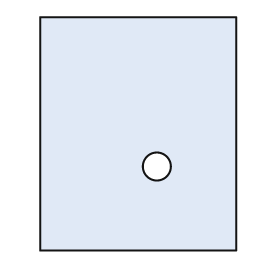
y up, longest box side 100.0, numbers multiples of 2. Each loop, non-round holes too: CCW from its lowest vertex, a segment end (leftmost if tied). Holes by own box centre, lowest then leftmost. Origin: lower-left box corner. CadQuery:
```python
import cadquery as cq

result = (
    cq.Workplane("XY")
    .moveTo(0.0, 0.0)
    .lineTo(84.0, 0.0)
    .lineTo(84.0, 100.0)
    .lineTo(0.0, 100.0)
    .close()
    .moveTo(50.0, 36.0)
    .circle(6.0)
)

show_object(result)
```